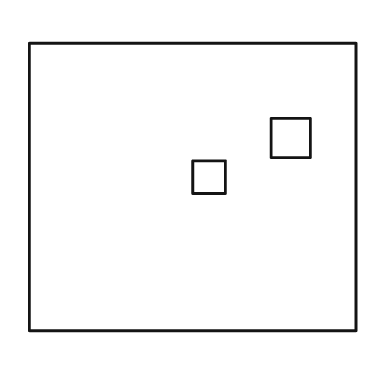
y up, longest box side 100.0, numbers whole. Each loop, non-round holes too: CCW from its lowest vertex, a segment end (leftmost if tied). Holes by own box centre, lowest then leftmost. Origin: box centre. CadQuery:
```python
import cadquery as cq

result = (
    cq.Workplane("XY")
    .moveTo(-50.0, -44.0)
    .lineTo(50.0, -44.0)
    .lineTo(50.0, 44.0)
    .lineTo(-50.0, 44.0)
    .close()
    .moveTo(0.0, -2.0)
    .lineTo(10.0, -2.0)
    .lineTo(10.0, 8.0)
    .lineTo(0.0, 8.0)
    .close()
    .moveTo(24.0, 9.0)
    .lineTo(36.0, 9.0)
    .lineTo(36.0, 21.0)
    .lineTo(24.0, 21.0)
    .close()
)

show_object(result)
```